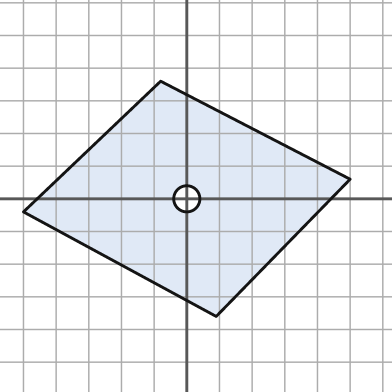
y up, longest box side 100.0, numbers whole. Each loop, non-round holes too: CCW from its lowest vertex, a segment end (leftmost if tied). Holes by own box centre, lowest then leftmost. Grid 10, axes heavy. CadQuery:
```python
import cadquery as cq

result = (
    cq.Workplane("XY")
    .moveTo(9.0, -36.0)
    .lineTo(50.0, 6.0)
    .lineTo(-8.0, 36.0)
    .lineTo(-50.0, -4.0)
    .close()
    .moveTo(0.0, 0.0)
    .circle(4.0)
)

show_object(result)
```